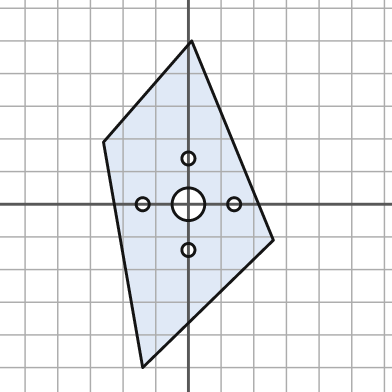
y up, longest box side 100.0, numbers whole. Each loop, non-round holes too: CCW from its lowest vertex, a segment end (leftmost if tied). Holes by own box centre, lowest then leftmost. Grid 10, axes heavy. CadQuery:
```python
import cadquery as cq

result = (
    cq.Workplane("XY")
    .moveTo(-14.0, -50.0)
    .lineTo(26.0, -11.0)
    .lineTo(1.0, 50.0)
    .lineTo(-26.0, 19.0)
    .close()
    .moveTo(0.0, -14.0)
    .circle(2.0)
    .moveTo(-14.0, 0.0)
    .circle(2.0)
    .moveTo(0.0, 0.0)
    .circle(5.0)
    .moveTo(14.0, 0.0)
    .circle(2.0)
    .moveTo(0.0, 14.0)
    .circle(2.0)
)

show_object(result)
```